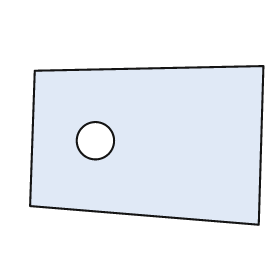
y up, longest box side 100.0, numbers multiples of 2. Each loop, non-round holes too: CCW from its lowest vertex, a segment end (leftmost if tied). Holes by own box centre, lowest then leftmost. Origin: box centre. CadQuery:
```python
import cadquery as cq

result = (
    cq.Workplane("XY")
    .moveTo(48.0, -34.0)
    .lineTo(50.0, 34.0)
    .lineTo(-48.0, 32.0)
    .lineTo(-50.0, -26.0)
    .close()
    .moveTo(-22.0, 2.0)
    .circle(8.0)
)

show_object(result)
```